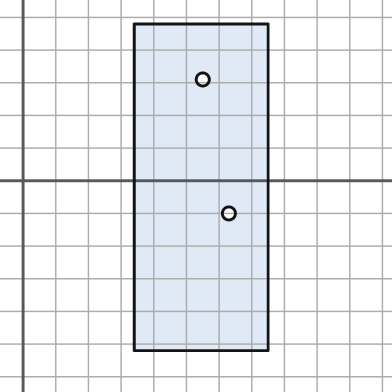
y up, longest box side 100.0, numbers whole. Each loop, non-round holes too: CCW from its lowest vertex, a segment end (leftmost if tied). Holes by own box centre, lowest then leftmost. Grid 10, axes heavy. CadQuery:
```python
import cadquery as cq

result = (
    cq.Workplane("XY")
    .moveTo(34.0, -52.0)
    .lineTo(75.0, -52.0)
    .lineTo(75.0, 48.0)
    .lineTo(34.0, 48.0)
    .close()
    .moveTo(63.0, -10.0)
    .circle(2.0)
    .moveTo(55.0, 31.0)
    .circle(2.0)
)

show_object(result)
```